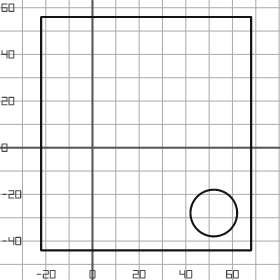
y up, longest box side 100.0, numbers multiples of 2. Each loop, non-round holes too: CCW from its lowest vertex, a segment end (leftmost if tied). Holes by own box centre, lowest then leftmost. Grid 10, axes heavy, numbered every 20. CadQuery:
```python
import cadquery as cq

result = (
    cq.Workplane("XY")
    .moveTo(-22.0, -44.0)
    .lineTo(68.0, -44.0)
    .lineTo(68.0, 56.0)
    .lineTo(-22.0, 56.0)
    .close()
    .moveTo(52.0, -28.0)
    .circle(10.0)
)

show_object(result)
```